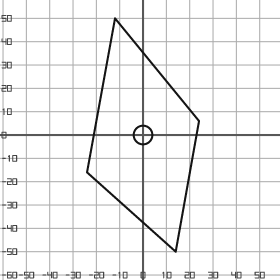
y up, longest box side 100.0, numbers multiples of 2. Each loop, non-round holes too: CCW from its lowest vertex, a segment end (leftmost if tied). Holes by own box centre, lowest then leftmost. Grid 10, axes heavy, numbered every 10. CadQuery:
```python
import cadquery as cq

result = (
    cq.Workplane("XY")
    .moveTo(14.0, -50.0)
    .lineTo(24.0, 6.0)
    .lineTo(-12.0, 50.0)
    .lineTo(-24.0, -16.0)
    .close()
    .moveTo(0.0, 0.0)
    .circle(4.0)
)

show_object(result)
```